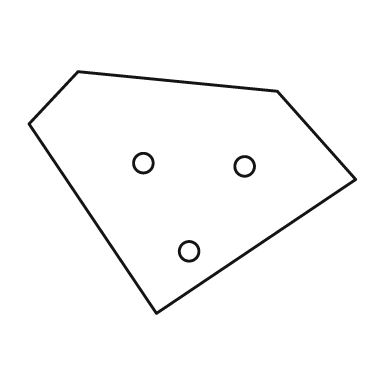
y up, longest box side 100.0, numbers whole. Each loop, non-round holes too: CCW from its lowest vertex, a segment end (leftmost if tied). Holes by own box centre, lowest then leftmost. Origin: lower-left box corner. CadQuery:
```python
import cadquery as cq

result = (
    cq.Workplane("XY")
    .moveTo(39.0, 0.0)
    .lineTo(100.0, 41.0)
    .lineTo(76.0, 68.0)
    .lineTo(15.0, 74.0)
    .lineTo(0.0, 58.0)
    .close()
    .moveTo(49.0, 19.0)
    .circle(3.0)
    .moveTo(66.0, 45.0)
    .circle(3.0)
    .moveTo(35.0, 46.0)
    .circle(3.0)
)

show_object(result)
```